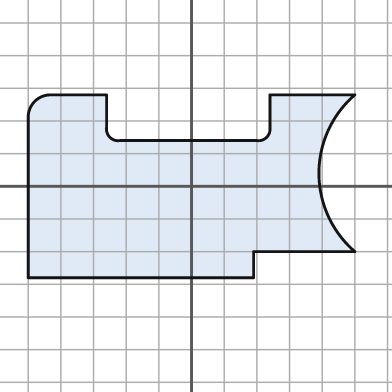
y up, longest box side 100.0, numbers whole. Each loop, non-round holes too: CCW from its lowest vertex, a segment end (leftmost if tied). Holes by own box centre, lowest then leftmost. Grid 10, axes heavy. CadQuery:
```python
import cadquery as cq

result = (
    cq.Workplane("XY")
    .moveTo(-50.0, -28.0)
    .lineTo(19.0, -28.0)
    .lineTo(19.0, -20.0)
    .lineTo(50.0, -20.0)
    .threePointArc((39.0, 4.0), (50.0, 28.0))
    .lineTo(24.0, 28.0)
    .lineTo(24.0, 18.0)
    .threePointArc((23.0, 15.0), (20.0, 14.0))
    .lineTo(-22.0, 14.0)
    .threePointArc((-25.0, 15.0), (-26.0, 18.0))
    .lineTo(-26.0, 28.0)
    .lineTo(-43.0, 28.0)
    .threePointArc((-48.0, 26.0), (-50.0, 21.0))
    .close()
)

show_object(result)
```